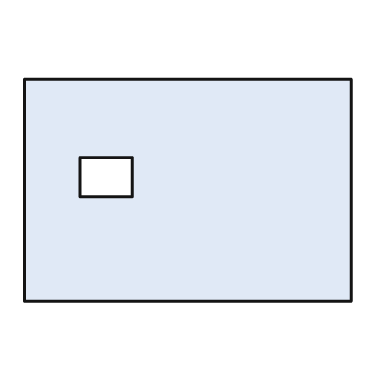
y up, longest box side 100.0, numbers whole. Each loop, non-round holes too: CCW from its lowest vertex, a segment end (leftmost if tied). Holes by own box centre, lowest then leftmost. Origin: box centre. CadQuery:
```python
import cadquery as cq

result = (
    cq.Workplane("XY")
    .moveTo(-50.0, -34.0)
    .lineTo(50.0, -34.0)
    .lineTo(50.0, 34.0)
    .lineTo(-50.0, 34.0)
    .close()
    .moveTo(-33.0, -2.0)
    .lineTo(-17.0, -2.0)
    .lineTo(-17.0, 10.0)
    .lineTo(-33.0, 10.0)
    .close()
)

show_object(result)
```